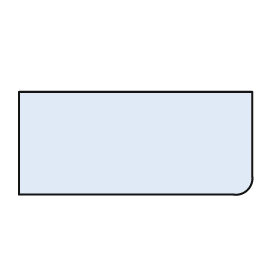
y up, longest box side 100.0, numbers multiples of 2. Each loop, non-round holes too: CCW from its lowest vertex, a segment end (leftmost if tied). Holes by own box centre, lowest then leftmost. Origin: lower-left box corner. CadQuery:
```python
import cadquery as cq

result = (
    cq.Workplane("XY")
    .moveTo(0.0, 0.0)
    .lineTo(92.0, 0.0)
    .threePointArc((98.0, 2.0), (100.0, 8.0))
    .lineTo(100.0, 44.0)
    .lineTo(0.0, 44.0)
    .close()
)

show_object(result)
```